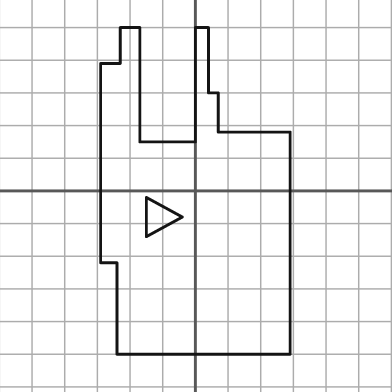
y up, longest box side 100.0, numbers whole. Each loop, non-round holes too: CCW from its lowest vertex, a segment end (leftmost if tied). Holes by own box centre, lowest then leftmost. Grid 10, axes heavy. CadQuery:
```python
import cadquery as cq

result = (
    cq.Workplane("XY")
    .moveTo(-24.0, -50.0)
    .lineTo(29.0, -50.0)
    .lineTo(29.0, 18.0)
    .lineTo(7.0, 18.0)
    .lineTo(7.0, 30.0)
    .lineTo(4.0, 30.0)
    .lineTo(4.0, 50.0)
    .lineTo(0.0, 50.0)
    .lineTo(0.0, 15.0)
    .lineTo(-17.0, 15.0)
    .lineTo(-17.0, 50.0)
    .lineTo(-23.0, 50.0)
    .lineTo(-23.0, 39.0)
    .lineTo(-29.0, 39.0)
    .lineTo(-29.0, -22.0)
    .lineTo(-24.0, -22.0)
    .close()
    .moveTo(-15.0, -14.0)
    .lineTo(-4.0, -8.0)
    .lineTo(-15.0, -2.0)
    .close()
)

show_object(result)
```